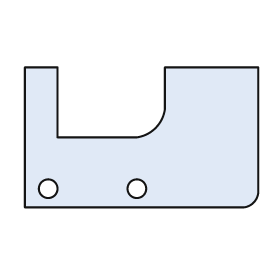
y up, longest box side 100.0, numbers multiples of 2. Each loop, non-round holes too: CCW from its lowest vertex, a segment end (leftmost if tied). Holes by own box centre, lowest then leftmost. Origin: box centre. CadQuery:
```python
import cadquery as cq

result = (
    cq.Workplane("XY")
    .moveTo(-50.0, -30.0)
    .lineTo(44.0, -30.0)
    .threePointArc((48.0, -28.0), (50.0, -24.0))
    .lineTo(50.0, 30.0)
    .lineTo(10.0, 30.0)
    .lineTo(10.0, 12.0)
    .threePointArc((6.0, 4.0), (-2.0, 0.0))
    .lineTo(-36.0, 0.0)
    .lineTo(-36.0, 30.0)
    .lineTo(-50.0, 30.0)
    .close()
    .moveTo(-40.0, -22.0)
    .circle(4.0)
    .moveTo(-2.0, -22.0)
    .circle(4.0)
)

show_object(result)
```